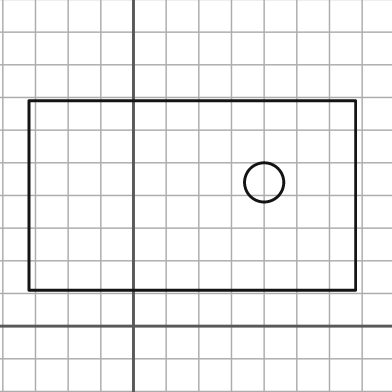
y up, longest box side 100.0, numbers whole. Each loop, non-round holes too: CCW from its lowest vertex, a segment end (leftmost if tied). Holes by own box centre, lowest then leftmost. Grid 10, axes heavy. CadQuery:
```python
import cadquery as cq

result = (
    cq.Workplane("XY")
    .moveTo(-32.0, 11.0)
    .lineTo(68.0, 11.0)
    .lineTo(68.0, 69.0)
    .lineTo(-32.0, 69.0)
    .close()
    .moveTo(40.0, 44.0)
    .circle(6.0)
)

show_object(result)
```